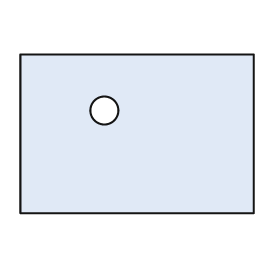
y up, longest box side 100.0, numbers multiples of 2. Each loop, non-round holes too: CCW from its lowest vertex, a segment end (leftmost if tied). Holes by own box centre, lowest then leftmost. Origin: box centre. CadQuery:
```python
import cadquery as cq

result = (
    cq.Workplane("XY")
    .moveTo(-50.0, -34.0)
    .lineTo(50.0, -34.0)
    .lineTo(50.0, 34.0)
    .lineTo(-50.0, 34.0)
    .close()
    .moveTo(-14.0, 10.0)
    .circle(6.0)
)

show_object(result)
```